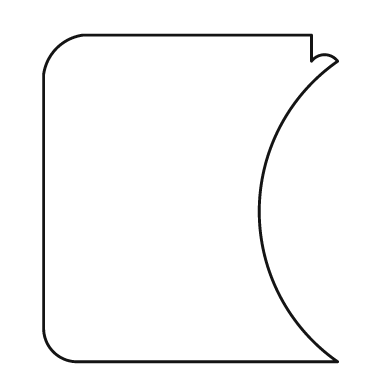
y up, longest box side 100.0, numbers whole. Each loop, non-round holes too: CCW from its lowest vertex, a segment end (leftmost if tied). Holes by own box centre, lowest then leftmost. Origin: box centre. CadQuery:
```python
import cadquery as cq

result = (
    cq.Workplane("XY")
    .moveTo(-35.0, -50.0)
    .lineTo(45.0, -50.0)
    .threePointArc((21.0, -4.0), (45.0, 42.0))
    .threePointArc((41.0, 44.0), (37.0, 42.0))
    .lineTo(37.0, 50.0)
    .lineTo(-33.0, 50.0)
    .threePointArc((-41.0, 46.0), (-45.0, 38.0))
    .lineTo(-45.0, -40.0)
    .threePointArc((-42.0, -47.0), (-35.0, -50.0))
    .close()
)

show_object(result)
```